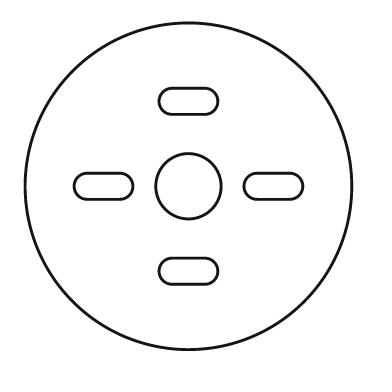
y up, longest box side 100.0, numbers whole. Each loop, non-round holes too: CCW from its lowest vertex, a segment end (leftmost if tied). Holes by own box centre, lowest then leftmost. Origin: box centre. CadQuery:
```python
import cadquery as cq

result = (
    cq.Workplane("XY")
    .moveTo(0.0, 0.0)
    .circle(50.0)
    .moveTo(-5.0, -30.0)
    .lineTo(5.0, -30.0)
    .threePointArc((9.0, -26.0), (5.0, -22.0))
    .lineTo(-5.0, -22.0)
    .threePointArc((-9.0, -26.0), (-5.0, -30.0))
    .close()
    .moveTo(-31.0, -4.0)
    .lineTo(-21.0, -4.0)
    .threePointArc((-17.0, 0.0), (-21.0, 4.0))
    .lineTo(-31.0, 4.0)
    .threePointArc((-35.0, 0.0), (-31.0, -4.0))
    .close()
    .moveTo(0.0, 0.0)
    .circle(10.0)
    .moveTo(21.0, -4.0)
    .lineTo(31.0, -4.0)
    .threePointArc((35.0, 0.0), (31.0, 4.0))
    .lineTo(21.0, 4.0)
    .threePointArc((17.0, 0.0), (21.0, -4.0))
    .close()
    .moveTo(-5.0, 22.0)
    .lineTo(5.0, 22.0)
    .threePointArc((9.0, 26.0), (5.0, 30.0))
    .lineTo(-5.0, 30.0)
    .threePointArc((-9.0, 26.0), (-5.0, 22.0))
    .close()
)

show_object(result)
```